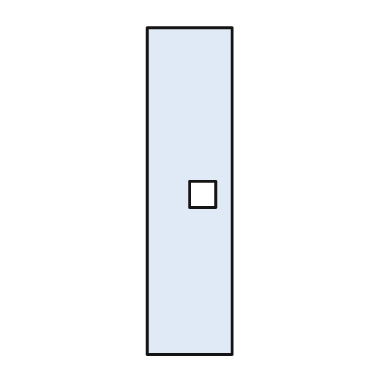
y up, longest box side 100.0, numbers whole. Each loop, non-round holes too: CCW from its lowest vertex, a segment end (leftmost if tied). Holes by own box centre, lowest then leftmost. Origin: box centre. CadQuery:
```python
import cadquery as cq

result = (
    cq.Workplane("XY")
    .moveTo(-13.0, -50.0)
    .lineTo(13.0, -50.0)
    .lineTo(13.0, 50.0)
    .lineTo(-13.0, 50.0)
    .close()
    .moveTo(0.0, -5.0)
    .lineTo(8.0, -5.0)
    .lineTo(8.0, 3.0)
    .lineTo(0.0, 3.0)
    .close()
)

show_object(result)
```